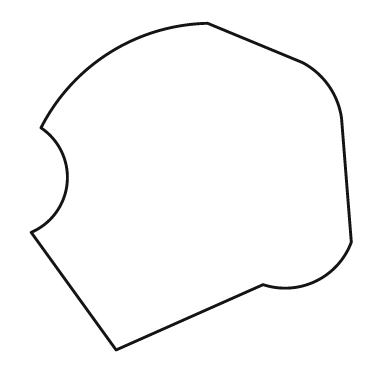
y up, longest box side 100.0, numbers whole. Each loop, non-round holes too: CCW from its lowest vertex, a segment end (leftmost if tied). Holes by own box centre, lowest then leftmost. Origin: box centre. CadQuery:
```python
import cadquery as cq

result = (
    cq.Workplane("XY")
    .moveTo(-23.0, -50.0)
    .lineTo(22.0, -30.0)
    .threePointArc((38.0, -29.0), (49.0, -17.0))
    .lineTo(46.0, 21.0)
    .threePointArc((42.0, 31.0), (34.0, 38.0))
    .lineTo(5.0, 50.0)
    .threePointArc((-25.0, 41.0), (-46.0, 18.0))
    .threePointArc((-38.0, 1.0), (-49.0, -14.0))
    .close()
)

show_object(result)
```